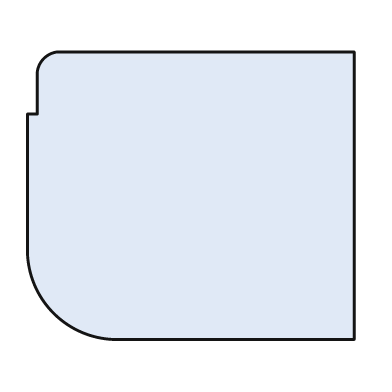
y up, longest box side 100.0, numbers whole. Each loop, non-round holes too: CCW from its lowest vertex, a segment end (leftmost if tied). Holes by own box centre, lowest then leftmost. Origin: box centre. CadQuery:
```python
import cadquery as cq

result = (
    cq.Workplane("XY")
    .moveTo(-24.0, -44.0)
    .lineTo(50.0, -44.0)
    .lineTo(50.0, 44.0)
    .lineTo(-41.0, 44.0)
    .threePointArc((-45.0, 42.0), (-47.0, 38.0))
    .lineTo(-47.0, 25.0)
    .lineTo(-50.0, 25.0)
    .lineTo(-50.0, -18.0)
    .threePointArc((-42.0, -36.0), (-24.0, -44.0))
    .close()
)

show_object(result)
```